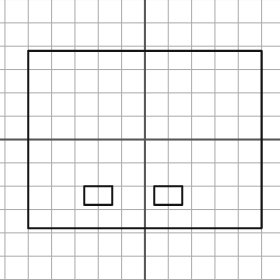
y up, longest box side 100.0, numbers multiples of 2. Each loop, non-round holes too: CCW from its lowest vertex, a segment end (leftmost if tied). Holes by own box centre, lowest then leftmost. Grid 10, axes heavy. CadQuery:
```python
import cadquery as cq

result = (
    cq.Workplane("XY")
    .moveTo(-50.0, -38.0)
    .lineTo(50.0, -38.0)
    .lineTo(50.0, 38.0)
    .lineTo(-50.0, 38.0)
    .close()
    .moveTo(-26.0, -28.0)
    .lineTo(-14.0, -28.0)
    .lineTo(-14.0, -20.0)
    .lineTo(-26.0, -20.0)
    .close()
    .moveTo(4.0, -28.0)
    .lineTo(16.0, -28.0)
    .lineTo(16.0, -20.0)
    .lineTo(4.0, -20.0)
    .close()
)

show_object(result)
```